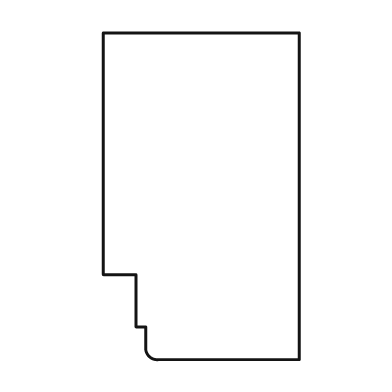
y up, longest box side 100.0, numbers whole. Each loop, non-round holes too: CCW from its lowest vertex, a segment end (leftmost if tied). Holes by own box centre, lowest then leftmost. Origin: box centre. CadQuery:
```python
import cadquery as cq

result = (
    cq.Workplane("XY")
    .moveTo(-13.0, -50.0)
    .lineTo(30.0, -50.0)
    .lineTo(30.0, 50.0)
    .lineTo(-30.0, 50.0)
    .lineTo(-30.0, -24.0)
    .lineTo(-20.0, -24.0)
    .lineTo(-20.0, -40.0)
    .lineTo(-17.0, -40.0)
    .lineTo(-17.0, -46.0)
    .threePointArc((-16.0, -49.0), (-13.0, -50.0))
    .close()
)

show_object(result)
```